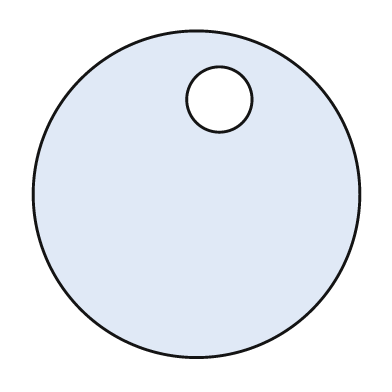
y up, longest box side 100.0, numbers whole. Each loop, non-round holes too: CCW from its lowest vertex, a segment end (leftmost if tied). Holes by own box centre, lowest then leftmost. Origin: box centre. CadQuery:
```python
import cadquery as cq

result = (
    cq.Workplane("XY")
    .moveTo(0.0, 0.0)
    .circle(50.0)
    .moveTo(7.0, 29.0)
    .circle(10.0)
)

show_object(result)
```